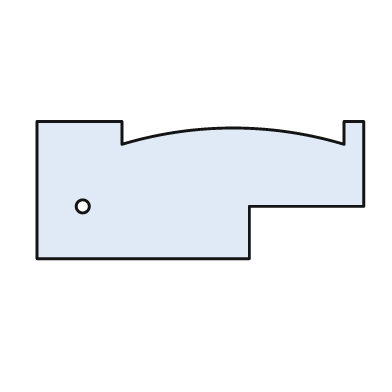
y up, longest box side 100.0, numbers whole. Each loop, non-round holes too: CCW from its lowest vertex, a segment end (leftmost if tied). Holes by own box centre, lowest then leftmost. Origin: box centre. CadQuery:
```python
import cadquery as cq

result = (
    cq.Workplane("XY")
    .moveTo(-50.0, -21.0)
    .lineTo(15.0, -21.0)
    .lineTo(15.0, -5.0)
    .lineTo(50.0, -5.0)
    .lineTo(50.0, 21.0)
    .lineTo(44.0, 21.0)
    .lineTo(44.0, 14.0)
    .threePointArc((10.0, 19.0), (-24.0, 14.0))
    .lineTo(-24.0, 21.0)
    .lineTo(-50.0, 21.0)
    .close()
    .moveTo(-36.0, -5.0)
    .circle(2.0)
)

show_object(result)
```